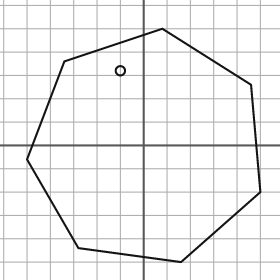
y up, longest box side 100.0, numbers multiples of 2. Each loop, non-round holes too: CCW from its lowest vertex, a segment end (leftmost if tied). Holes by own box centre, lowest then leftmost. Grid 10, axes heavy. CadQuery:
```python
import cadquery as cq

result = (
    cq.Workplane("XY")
    .moveTo(16.0, -50.0)
    .lineTo(50.0, -20.0)
    .lineTo(46.0, 26.0)
    .lineTo(8.0, 50.0)
    .lineTo(-34.0, 36.0)
    .lineTo(-50.0, -6.0)
    .lineTo(-28.0, -44.0)
    .close()
    .moveTo(-10.0, 32.0)
    .circle(2.0)
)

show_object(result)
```